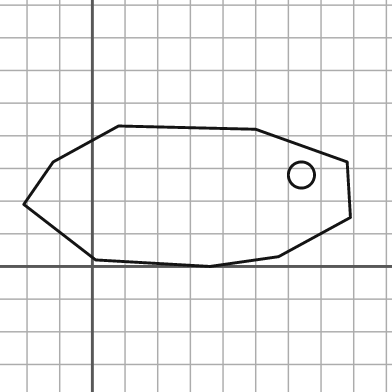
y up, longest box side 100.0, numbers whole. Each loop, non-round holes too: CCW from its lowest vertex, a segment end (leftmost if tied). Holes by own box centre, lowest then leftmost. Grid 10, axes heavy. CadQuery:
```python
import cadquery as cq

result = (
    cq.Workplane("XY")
    .moveTo(36.0, 0.0)
    .lineTo(57.0, 3.0)
    .lineTo(79.0, 15.0)
    .lineTo(78.0, 32.0)
    .lineTo(50.0, 42.0)
    .lineTo(8.0, 43.0)
    .lineTo(-12.0, 32.0)
    .lineTo(-21.0, 19.0)
    .lineTo(1.0, 2.0)
    .close()
    .moveTo(64.0, 28.0)
    .circle(4.0)
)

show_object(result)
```